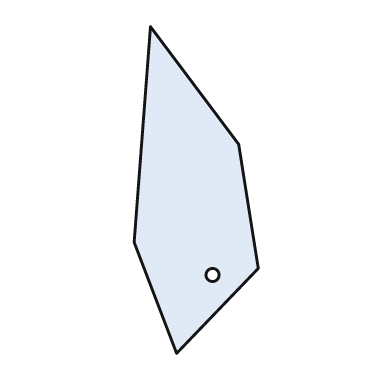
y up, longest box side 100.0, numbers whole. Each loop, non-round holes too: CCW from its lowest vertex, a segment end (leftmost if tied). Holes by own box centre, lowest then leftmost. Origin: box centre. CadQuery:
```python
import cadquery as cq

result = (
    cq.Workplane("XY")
    .moveTo(-6.0, -50.0)
    .lineTo(19.0, -24.0)
    .lineTo(13.0, 14.0)
    .lineTo(-14.0, 50.0)
    .lineTo(-19.0, -16.0)
    .close()
    .moveTo(5.0, -26.0)
    .circle(2.0)
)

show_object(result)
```